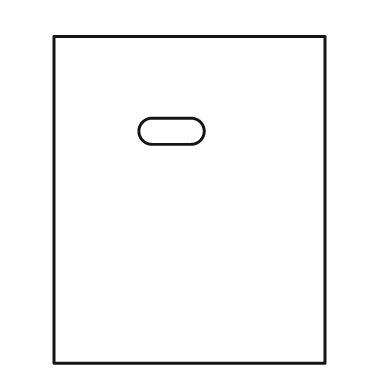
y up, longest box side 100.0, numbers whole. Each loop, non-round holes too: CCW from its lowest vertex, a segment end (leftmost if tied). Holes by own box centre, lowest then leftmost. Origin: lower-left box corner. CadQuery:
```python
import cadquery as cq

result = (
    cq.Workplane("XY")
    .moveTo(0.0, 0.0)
    .lineTo(83.0, 0.0)
    .lineTo(83.0, 100.0)
    .lineTo(0.0, 100.0)
    .close()
    .moveTo(30.0, 67.0)
    .lineTo(42.0, 67.0)
    .threePointArc((46.0, 71.0), (42.0, 75.0))
    .lineTo(30.0, 75.0)
    .threePointArc((26.0, 71.0), (30.0, 67.0))
    .close()
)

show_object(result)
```